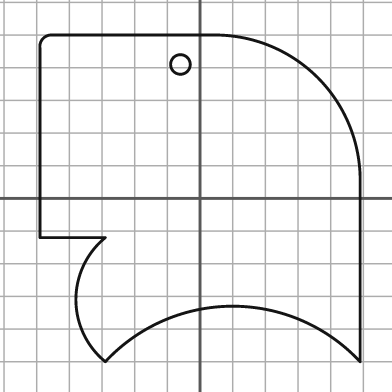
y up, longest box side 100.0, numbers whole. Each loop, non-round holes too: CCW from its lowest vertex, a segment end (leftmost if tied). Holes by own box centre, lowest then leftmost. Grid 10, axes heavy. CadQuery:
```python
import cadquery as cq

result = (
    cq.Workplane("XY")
    .moveTo(-29.0, -50.0)
    .threePointArc((10.0, -33.0), (49.0, -50.0))
    .lineTo(49.0, 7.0)
    .threePointArc((36.0, 37.0), (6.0, 50.0))
    .lineTo(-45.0, 50.0)
    .threePointArc((-48.0, 49.0), (-49.0, 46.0))
    .lineTo(-49.0, -12.0)
    .lineTo(-29.0, -12.0)
    .threePointArc((-38.0, -31.0), (-29.0, -50.0))
    .close()
    .moveTo(-6.0, 41.0)
    .circle(3.0)
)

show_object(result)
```